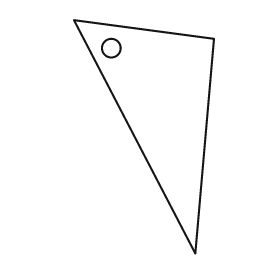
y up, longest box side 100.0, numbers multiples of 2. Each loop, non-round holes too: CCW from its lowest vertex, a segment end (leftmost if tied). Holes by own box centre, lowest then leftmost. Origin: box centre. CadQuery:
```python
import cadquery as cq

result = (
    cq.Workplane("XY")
    .moveTo(22.0, -50.0)
    .lineTo(30.0, 42.0)
    .lineTo(-30.0, 50.0)
    .close()
    .moveTo(-14.0, 38.0)
    .circle(4.0)
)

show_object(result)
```